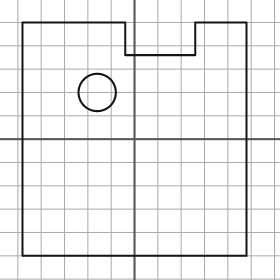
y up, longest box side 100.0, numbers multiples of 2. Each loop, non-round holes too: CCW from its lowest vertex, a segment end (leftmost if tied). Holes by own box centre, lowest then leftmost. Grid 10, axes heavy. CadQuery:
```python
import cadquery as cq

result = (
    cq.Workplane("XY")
    .moveTo(-48.0, -50.0)
    .lineTo(48.0, -50.0)
    .lineTo(48.0, 50.0)
    .lineTo(26.0, 50.0)
    .lineTo(26.0, 36.0)
    .lineTo(-4.0, 36.0)
    .lineTo(-4.0, 50.0)
    .lineTo(-48.0, 50.0)
    .close()
    .moveTo(-16.0, 20.0)
    .circle(8.0)
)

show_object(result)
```